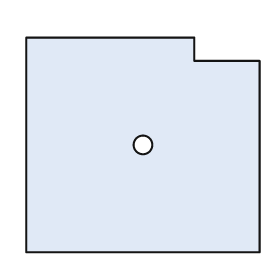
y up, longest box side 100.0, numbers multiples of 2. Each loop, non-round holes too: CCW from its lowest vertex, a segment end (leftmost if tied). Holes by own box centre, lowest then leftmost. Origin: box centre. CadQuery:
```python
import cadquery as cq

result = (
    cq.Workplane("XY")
    .moveTo(-50.0, -46.0)
    .lineTo(50.0, -46.0)
    .lineTo(50.0, 36.0)
    .lineTo(22.0, 36.0)
    .lineTo(22.0, 46.0)
    .lineTo(-50.0, 46.0)
    .close()
    .moveTo(0.0, 0.0)
    .circle(4.0)
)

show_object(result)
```